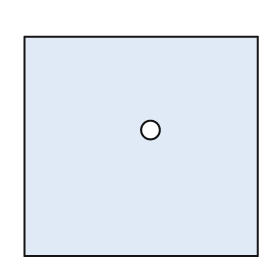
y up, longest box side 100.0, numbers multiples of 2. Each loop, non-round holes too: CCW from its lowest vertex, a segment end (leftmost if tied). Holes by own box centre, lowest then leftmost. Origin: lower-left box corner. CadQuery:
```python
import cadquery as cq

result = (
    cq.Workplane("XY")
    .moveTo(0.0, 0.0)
    .lineTo(100.0, 0.0)
    .lineTo(100.0, 94.0)
    .lineTo(0.0, 94.0)
    .close()
    .moveTo(54.0, 54.0)
    .circle(4.0)
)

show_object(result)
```